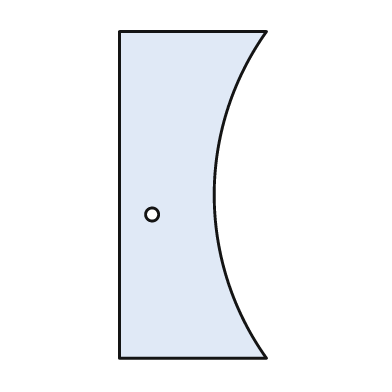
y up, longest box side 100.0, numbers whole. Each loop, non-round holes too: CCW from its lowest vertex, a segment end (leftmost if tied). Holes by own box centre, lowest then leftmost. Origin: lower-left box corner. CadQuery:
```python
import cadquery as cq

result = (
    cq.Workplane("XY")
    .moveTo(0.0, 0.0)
    .lineTo(45.0, 0.0)
    .threePointArc((29.0, 50.0), (45.0, 100.0))
    .lineTo(0.0, 100.0)
    .close()
    .moveTo(10.0, 44.0)
    .circle(2.0)
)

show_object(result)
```